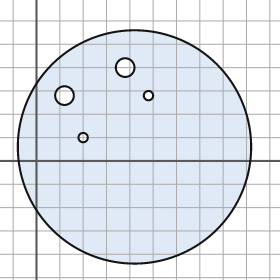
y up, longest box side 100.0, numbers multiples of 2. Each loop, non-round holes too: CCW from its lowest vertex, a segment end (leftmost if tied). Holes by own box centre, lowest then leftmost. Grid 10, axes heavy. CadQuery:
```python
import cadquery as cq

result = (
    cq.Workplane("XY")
    .moveTo(42.0, 6.0)
    .circle(50.0)
    .moveTo(20.0, 10.0)
    .circle(2.0)
    .moveTo(12.0, 28.0)
    .circle(4.0)
    .moveTo(48.0, 28.0)
    .circle(2.0)
    .moveTo(38.0, 40.0)
    .circle(4.0)
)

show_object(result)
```